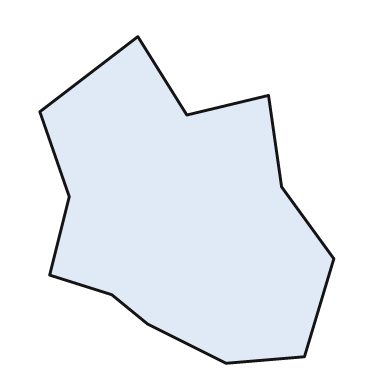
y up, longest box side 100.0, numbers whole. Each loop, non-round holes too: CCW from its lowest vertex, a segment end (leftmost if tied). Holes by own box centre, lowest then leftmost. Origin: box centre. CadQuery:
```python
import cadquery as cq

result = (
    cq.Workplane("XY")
    .moveTo(12.0, -50.0)
    .lineTo(36.0, -48.0)
    .lineTo(45.0, -18.0)
    .lineTo(29.0, 4.0)
    .lineTo(25.0, 32.0)
    .lineTo(0.0, 26.0)
    .lineTo(-15.0, 50.0)
    .lineTo(-45.0, 27.0)
    .lineTo(-36.0, 1.0)
    .lineTo(-42.0, -23.0)
    .lineTo(-23.0, -29.0)
    .lineTo(-12.0, -38.0)
    .close()
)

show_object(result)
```